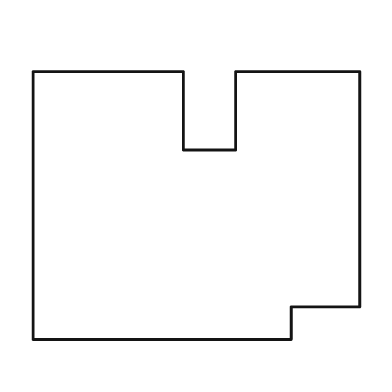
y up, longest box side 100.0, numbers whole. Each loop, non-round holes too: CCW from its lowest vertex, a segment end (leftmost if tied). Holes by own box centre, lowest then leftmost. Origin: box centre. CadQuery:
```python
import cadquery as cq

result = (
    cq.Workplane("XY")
    .moveTo(-50.0, -41.0)
    .lineTo(29.0, -41.0)
    .lineTo(29.0, -31.0)
    .lineTo(50.0, -31.0)
    .lineTo(50.0, 41.0)
    .lineTo(12.0, 41.0)
    .lineTo(12.0, 17.0)
    .lineTo(-4.0, 17.0)
    .lineTo(-4.0, 41.0)
    .lineTo(-50.0, 41.0)
    .close()
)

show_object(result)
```